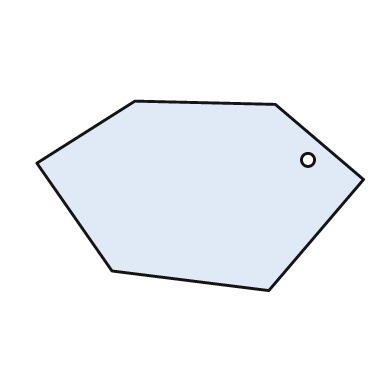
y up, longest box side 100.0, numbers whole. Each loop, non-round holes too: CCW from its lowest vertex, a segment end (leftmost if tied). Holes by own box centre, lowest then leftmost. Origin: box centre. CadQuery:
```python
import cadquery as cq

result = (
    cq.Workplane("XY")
    .moveTo(21.0, -29.0)
    .lineTo(50.0, 5.0)
    .lineTo(23.0, 28.0)
    .lineTo(-20.0, 29.0)
    .lineTo(-50.0, 10.0)
    .lineTo(-27.0, -23.0)
    .close()
    .moveTo(33.0, 11.0)
    .circle(2.0)
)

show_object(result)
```